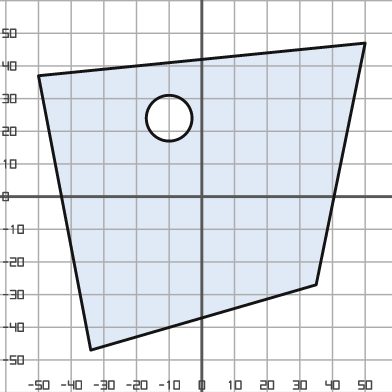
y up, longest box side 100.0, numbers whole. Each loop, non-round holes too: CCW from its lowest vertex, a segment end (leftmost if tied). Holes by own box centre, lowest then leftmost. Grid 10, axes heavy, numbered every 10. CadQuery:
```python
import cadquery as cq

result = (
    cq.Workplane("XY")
    .moveTo(-34.0, -47.0)
    .lineTo(35.0, -27.0)
    .lineTo(50.0, 47.0)
    .lineTo(-50.0, 37.0)
    .close()
    .moveTo(-10.0, 24.0)
    .circle(7.0)
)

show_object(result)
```